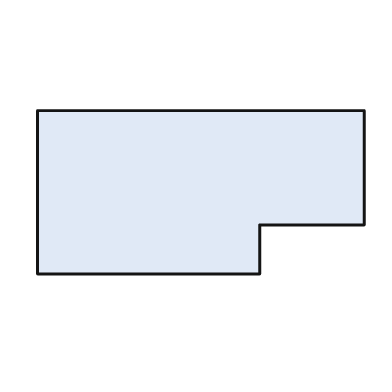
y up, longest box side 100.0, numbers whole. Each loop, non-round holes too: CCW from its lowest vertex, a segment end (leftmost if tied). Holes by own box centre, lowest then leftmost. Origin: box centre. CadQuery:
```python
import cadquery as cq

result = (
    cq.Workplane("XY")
    .moveTo(-50.0, -25.0)
    .lineTo(18.0, -25.0)
    .lineTo(18.0, -10.0)
    .lineTo(50.0, -10.0)
    .lineTo(50.0, 25.0)
    .lineTo(-50.0, 25.0)
    .close()
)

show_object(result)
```